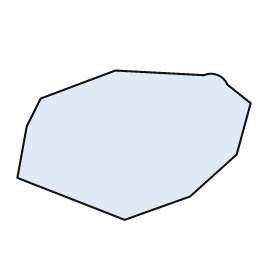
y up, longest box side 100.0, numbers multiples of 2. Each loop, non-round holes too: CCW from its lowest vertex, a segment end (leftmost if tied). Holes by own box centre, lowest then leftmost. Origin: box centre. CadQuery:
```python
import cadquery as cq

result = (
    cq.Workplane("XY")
    .moveTo(-4.0, -32.0)
    .lineTo(24.0, -22.0)
    .lineTo(44.0, -4.0)
    .lineTo(50.0, 18.0)
    .lineTo(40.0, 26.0)
    .threePointArc((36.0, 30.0), (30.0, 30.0))
    .lineTo(-8.0, 32.0)
    .lineTo(-40.0, 20.0)
    .lineTo(-46.0, 8.0)
    .lineTo(-50.0, -14.0)
    .close()
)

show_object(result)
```